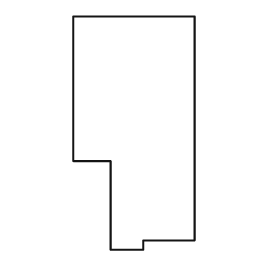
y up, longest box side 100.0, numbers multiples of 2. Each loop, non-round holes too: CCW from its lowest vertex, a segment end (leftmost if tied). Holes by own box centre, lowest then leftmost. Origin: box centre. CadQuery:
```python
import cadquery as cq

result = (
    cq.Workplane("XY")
    .moveTo(-10.0, -50.0)
    .lineTo(4.0, -50.0)
    .lineTo(4.0, -46.0)
    .lineTo(26.0, -46.0)
    .lineTo(26.0, 50.0)
    .lineTo(-26.0, 50.0)
    .lineTo(-26.0, -12.0)
    .lineTo(-10.0, -12.0)
    .close()
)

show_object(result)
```